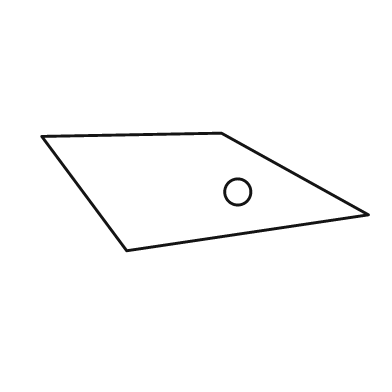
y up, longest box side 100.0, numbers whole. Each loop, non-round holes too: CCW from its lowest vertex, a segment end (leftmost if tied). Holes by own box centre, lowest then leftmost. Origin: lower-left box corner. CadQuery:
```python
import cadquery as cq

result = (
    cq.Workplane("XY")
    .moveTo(26.0, 0.0)
    .lineTo(100.0, 11.0)
    .lineTo(55.0, 36.0)
    .lineTo(0.0, 35.0)
    .close()
    .moveTo(60.0, 18.0)
    .circle(4.0)
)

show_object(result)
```